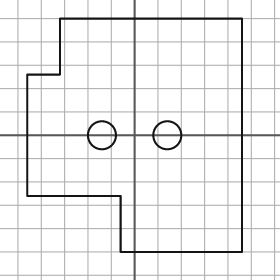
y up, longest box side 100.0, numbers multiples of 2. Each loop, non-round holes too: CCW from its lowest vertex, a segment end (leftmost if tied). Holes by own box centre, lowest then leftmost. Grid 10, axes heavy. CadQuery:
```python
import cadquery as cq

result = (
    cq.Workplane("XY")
    .moveTo(-6.0, -50.0)
    .lineTo(46.0, -50.0)
    .lineTo(46.0, 50.0)
    .lineTo(-32.0, 50.0)
    .lineTo(-32.0, 26.0)
    .lineTo(-46.0, 26.0)
    .lineTo(-46.0, -26.0)
    .lineTo(-6.0, -26.0)
    .close()
    .moveTo(-14.0, 0.0)
    .circle(6.0)
    .moveTo(14.0, 0.0)
    .circle(6.0)
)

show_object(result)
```